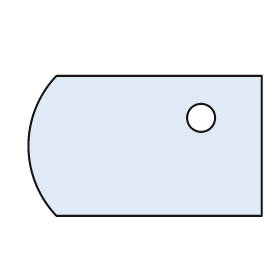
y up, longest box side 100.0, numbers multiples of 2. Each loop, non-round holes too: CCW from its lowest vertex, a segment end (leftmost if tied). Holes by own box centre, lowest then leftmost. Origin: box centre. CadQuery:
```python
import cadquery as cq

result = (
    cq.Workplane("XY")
    .moveTo(-38.0, -30.0)
    .lineTo(50.0, -30.0)
    .lineTo(50.0, 30.0)
    .lineTo(-38.0, 30.0)
    .threePointArc((-50.0, 0.0), (-38.0, -30.0))
    .close()
    .moveTo(24.0, 12.0)
    .circle(6.0)
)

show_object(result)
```